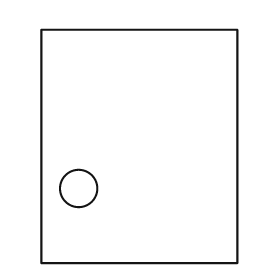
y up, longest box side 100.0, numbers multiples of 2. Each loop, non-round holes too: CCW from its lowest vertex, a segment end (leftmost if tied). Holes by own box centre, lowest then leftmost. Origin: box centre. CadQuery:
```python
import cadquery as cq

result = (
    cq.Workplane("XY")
    .moveTo(-42.0, -50.0)
    .lineTo(42.0, -50.0)
    .lineTo(42.0, 50.0)
    .lineTo(-42.0, 50.0)
    .close()
    .moveTo(-26.0, -18.0)
    .circle(8.0)
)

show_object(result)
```